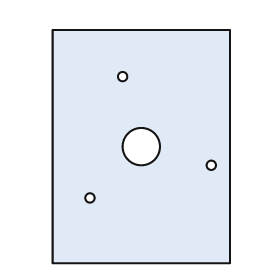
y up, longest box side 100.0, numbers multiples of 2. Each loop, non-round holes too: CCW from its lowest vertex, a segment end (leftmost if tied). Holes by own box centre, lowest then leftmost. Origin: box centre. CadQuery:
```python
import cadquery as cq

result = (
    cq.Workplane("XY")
    .moveTo(-38.0, -50.0)
    .lineTo(38.0, -50.0)
    .lineTo(38.0, 50.0)
    .lineTo(-38.0, 50.0)
    .close()
    .moveTo(-22.0, -22.0)
    .circle(2.0)
    .moveTo(30.0, -8.0)
    .circle(2.0)
    .moveTo(0.0, 0.0)
    .circle(8.0)
    .moveTo(-8.0, 30.0)
    .circle(2.0)
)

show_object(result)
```